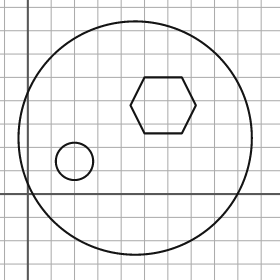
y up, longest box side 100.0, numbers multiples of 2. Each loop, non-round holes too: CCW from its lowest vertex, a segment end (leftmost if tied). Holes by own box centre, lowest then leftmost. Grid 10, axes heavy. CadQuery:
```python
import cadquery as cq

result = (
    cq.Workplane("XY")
    .moveTo(46.0, 24.0)
    .circle(50.0)
    .moveTo(20.0, 14.0)
    .circle(8.0)
    .moveTo(50.0, 26.0)
    .lineTo(66.0, 26.0)
    .lineTo(72.0, 38.0)
    .lineTo(66.0, 50.0)
    .lineTo(50.0, 50.0)
    .lineTo(44.0, 38.0)
    .close()
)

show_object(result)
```